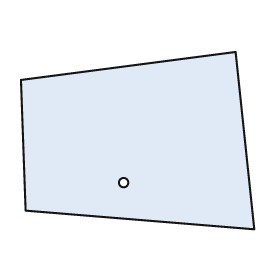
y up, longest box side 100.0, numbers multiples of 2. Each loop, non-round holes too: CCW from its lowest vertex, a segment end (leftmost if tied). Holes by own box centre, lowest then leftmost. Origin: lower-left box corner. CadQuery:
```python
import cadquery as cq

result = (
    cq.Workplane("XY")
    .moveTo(100.0, 0.0)
    .lineTo(92.0, 76.0)
    .lineTo(0.0, 64.0)
    .lineTo(2.0, 8.0)
    .close()
    .moveTo(44.0, 20.0)
    .circle(2.0)
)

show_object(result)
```